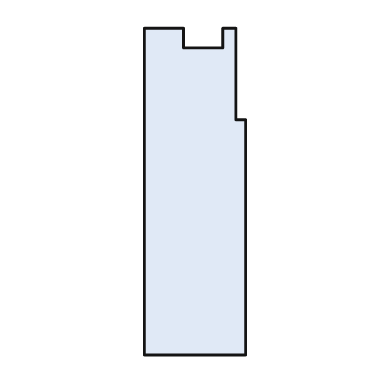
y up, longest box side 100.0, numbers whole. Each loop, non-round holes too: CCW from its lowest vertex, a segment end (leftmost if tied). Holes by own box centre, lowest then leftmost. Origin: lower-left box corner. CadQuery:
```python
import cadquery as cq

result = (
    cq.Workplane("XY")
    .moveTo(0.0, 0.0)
    .lineTo(31.0, 0.0)
    .lineTo(31.0, 72.0)
    .lineTo(28.0, 72.0)
    .lineTo(28.0, 100.0)
    .lineTo(24.0, 100.0)
    .lineTo(24.0, 94.0)
    .lineTo(12.0, 94.0)
    .lineTo(12.0, 100.0)
    .lineTo(0.0, 100.0)
    .close()
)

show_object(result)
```